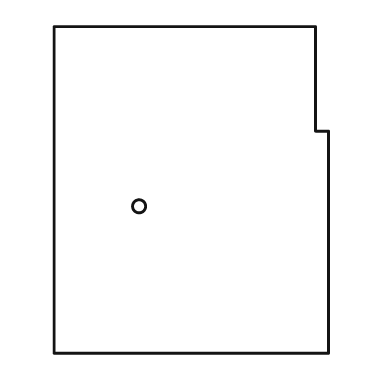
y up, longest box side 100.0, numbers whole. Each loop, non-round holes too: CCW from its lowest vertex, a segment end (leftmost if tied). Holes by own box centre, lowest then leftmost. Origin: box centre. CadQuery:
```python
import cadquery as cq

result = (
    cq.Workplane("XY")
    .moveTo(-42.0, -50.0)
    .lineTo(42.0, -50.0)
    .lineTo(42.0, 18.0)
    .lineTo(38.0, 18.0)
    .lineTo(38.0, 50.0)
    .lineTo(-42.0, 50.0)
    .close()
    .moveTo(-16.0, -5.0)
    .circle(2.0)
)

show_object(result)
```